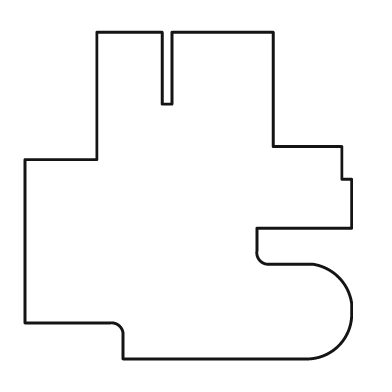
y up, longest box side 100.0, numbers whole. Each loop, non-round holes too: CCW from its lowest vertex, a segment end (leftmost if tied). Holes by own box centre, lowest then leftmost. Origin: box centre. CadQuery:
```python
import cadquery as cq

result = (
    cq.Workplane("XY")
    .moveTo(-20.0, -50.0)
    .lineTo(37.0, -50.0)
    .threePointArc((46.0, -46.0), (50.0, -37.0))
    .lineTo(50.0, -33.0)
    .threePointArc((46.0, -25.0), (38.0, -21.0))
    .lineTo(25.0, -21.0)
    .threePointArc((22.0, -20.0), (21.0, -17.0))
    .lineTo(21.0, -10.0)
    .lineTo(50.0, -10.0)
    .lineTo(50.0, 5.0)
    .lineTo(47.0, 5.0)
    .lineTo(47.0, 15.0)
    .lineTo(26.0, 15.0)
    .lineTo(26.0, 50.0)
    .lineTo(-5.0, 50.0)
    .lineTo(-5.0, 28.0)
    .lineTo(-8.0, 28.0)
    .lineTo(-8.0, 50.0)
    .lineTo(-28.0, 50.0)
    .lineTo(-28.0, 11.0)
    .lineTo(-50.0, 11.0)
    .lineTo(-50.0, -39.0)
    .lineTo(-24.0, -39.0)
    .threePointArc((-21.0, -40.0), (-20.0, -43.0))
    .close()
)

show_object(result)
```